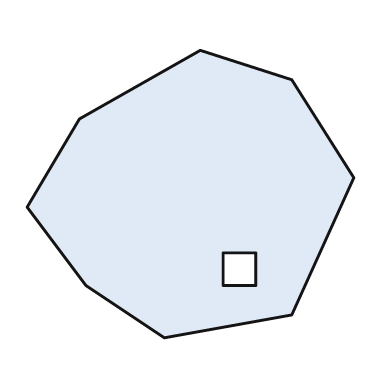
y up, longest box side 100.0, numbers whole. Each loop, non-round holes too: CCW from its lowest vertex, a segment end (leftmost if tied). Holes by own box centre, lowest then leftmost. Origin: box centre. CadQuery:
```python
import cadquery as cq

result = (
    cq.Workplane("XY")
    .moveTo(-8.0, -44.0)
    .lineTo(31.0, -37.0)
    .lineTo(50.0, 5.0)
    .lineTo(31.0, 35.0)
    .lineTo(3.0, 44.0)
    .lineTo(-34.0, 23.0)
    .lineTo(-50.0, -4.0)
    .lineTo(-32.0, -28.0)
    .close()
    .moveTo(10.0, -28.0)
    .lineTo(20.0, -28.0)
    .lineTo(20.0, -18.0)
    .lineTo(10.0, -18.0)
    .close()
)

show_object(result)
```